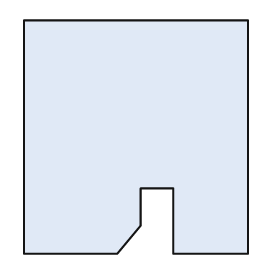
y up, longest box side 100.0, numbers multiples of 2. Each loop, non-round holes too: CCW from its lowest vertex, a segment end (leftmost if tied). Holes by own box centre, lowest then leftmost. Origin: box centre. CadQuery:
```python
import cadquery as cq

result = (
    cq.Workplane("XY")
    .moveTo(-48.0, -50.0)
    .lineTo(-8.0, -50.0)
    .lineTo(2.0, -38.0)
    .lineTo(2.0, -22.0)
    .lineTo(16.0, -22.0)
    .lineTo(16.0, -50.0)
    .lineTo(48.0, -50.0)
    .lineTo(48.0, 50.0)
    .lineTo(-48.0, 50.0)
    .close()
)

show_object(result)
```